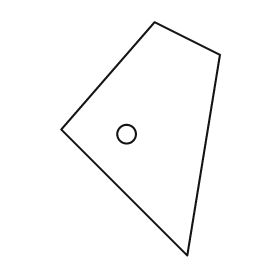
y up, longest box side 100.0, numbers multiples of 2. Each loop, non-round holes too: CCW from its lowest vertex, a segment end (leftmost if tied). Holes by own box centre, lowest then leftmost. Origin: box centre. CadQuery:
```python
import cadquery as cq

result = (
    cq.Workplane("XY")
    .moveTo(20.0, -50.0)
    .lineTo(34.0, 36.0)
    .lineTo(6.0, 50.0)
    .lineTo(-34.0, 4.0)
    .close()
    .moveTo(-6.0, 2.0)
    .circle(4.0)
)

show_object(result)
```